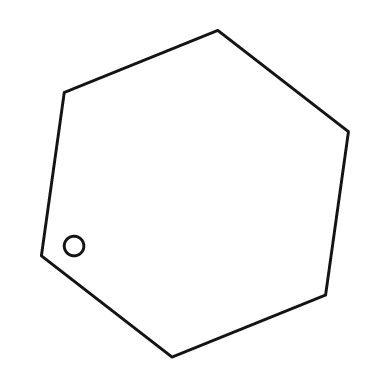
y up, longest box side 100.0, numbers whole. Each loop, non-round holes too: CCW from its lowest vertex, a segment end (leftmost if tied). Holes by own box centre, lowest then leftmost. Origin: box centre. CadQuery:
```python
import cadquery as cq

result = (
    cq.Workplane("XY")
    .moveTo(-7.0, -50.0)
    .lineTo(40.0, -31.0)
    .lineTo(47.0, 19.0)
    .lineTo(7.0, 50.0)
    .lineTo(-40.0, 31.0)
    .lineTo(-47.0, -19.0)
    .close()
    .moveTo(-37.0, -16.0)
    .circle(3.0)
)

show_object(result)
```